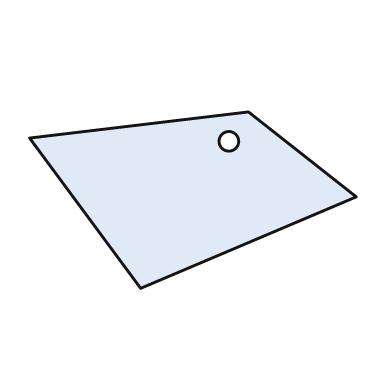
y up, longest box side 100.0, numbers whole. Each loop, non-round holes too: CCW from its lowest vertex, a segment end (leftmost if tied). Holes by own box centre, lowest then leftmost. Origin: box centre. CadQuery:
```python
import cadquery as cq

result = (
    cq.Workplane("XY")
    .moveTo(-16.0, -27.0)
    .lineTo(50.0, 1.0)
    .lineTo(17.0, 27.0)
    .lineTo(-50.0, 19.0)
    .close()
    .moveTo(11.0, 18.0)
    .circle(3.0)
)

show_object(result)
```